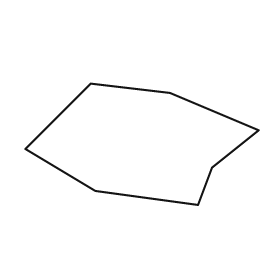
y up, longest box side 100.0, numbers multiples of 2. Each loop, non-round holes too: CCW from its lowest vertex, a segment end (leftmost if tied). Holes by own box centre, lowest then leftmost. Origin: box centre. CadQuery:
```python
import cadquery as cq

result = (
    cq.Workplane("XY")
    .moveTo(24.0, -26.0)
    .lineTo(30.0, -10.0)
    .lineTo(50.0, 6.0)
    .lineTo(12.0, 22.0)
    .lineTo(-22.0, 26.0)
    .lineTo(-50.0, -2.0)
    .lineTo(-20.0, -20.0)
    .close()
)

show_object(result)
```